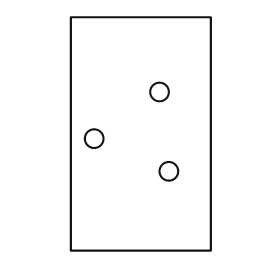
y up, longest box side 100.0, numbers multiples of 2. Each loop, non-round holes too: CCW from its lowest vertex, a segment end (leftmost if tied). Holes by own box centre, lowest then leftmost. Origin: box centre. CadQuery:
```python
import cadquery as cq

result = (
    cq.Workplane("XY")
    .moveTo(-30.0, -50.0)
    .lineTo(30.0, -50.0)
    .lineTo(30.0, 50.0)
    .lineTo(-30.0, 50.0)
    .close()
    .moveTo(12.0, -16.0)
    .circle(4.0)
    .moveTo(-20.0, -2.0)
    .circle(4.0)
    .moveTo(8.0, 18.0)
    .circle(4.0)
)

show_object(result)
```